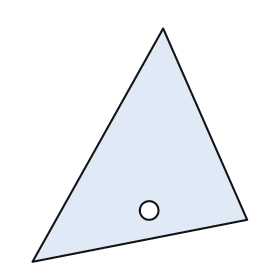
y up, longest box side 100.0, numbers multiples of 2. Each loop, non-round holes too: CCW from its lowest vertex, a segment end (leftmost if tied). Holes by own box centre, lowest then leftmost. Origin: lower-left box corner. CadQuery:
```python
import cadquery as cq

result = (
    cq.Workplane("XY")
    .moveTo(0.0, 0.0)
    .lineTo(92.0, 18.0)
    .lineTo(56.0, 100.0)
    .close()
    .moveTo(50.0, 22.0)
    .circle(4.0)
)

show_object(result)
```